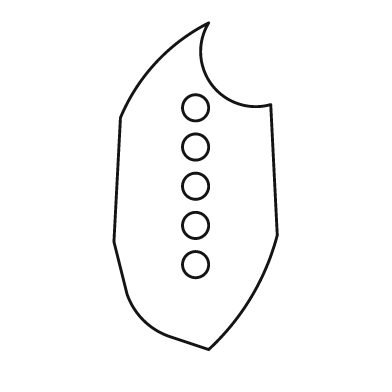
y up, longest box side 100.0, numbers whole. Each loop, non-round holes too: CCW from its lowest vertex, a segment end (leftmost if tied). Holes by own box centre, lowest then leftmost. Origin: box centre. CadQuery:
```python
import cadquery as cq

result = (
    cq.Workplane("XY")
    .moveTo(4.0, -50.0)
    .threePointArc((17.0, -34.0), (25.0, -15.0))
    .lineTo(23.0, 25.0)
    .threePointArc((5.0, 31.0), (4.0, 50.0))
    .threePointArc((-12.0, 38.0), (-23.0, 21.0))
    .lineTo(-25.0, -17.0)
    .lineTo(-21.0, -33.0)
    .threePointArc((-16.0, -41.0), (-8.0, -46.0))
    .close()
    .moveTo(0.0, -24.0)
    .circle(4.0)
    .moveTo(0.0, -12.0)
    .circle(4.0)
    .moveTo(0.0, 0.0)
    .circle(4.0)
    .moveTo(0.0, 12.0)
    .circle(4.0)
    .moveTo(0.0, 24.0)
    .circle(4.0)
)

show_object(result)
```